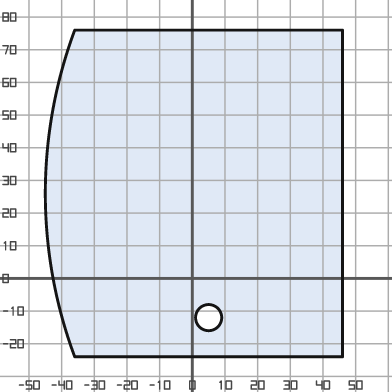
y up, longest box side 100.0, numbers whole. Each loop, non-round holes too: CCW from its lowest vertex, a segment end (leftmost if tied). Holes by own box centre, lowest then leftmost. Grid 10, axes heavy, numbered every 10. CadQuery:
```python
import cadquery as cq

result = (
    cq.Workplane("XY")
    .moveTo(-36.0, -24.0)
    .lineTo(46.0, -24.0)
    .lineTo(46.0, 76.0)
    .lineTo(-36.0, 76.0)
    .threePointArc((-45.0, 26.0), (-36.0, -24.0))
    .close()
    .moveTo(5.0, -12.0)
    .circle(4.0)
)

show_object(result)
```